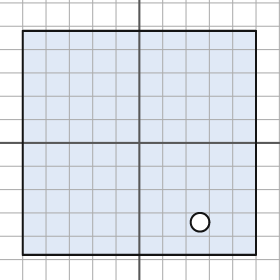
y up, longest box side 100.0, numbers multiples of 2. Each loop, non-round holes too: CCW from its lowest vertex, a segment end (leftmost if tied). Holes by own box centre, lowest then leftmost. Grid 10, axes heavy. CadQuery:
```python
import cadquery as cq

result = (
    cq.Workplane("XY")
    .moveTo(-50.0, -48.0)
    .lineTo(50.0, -48.0)
    .lineTo(50.0, 48.0)
    .lineTo(-50.0, 48.0)
    .close()
    .moveTo(26.0, -34.0)
    .circle(4.0)
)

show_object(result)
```